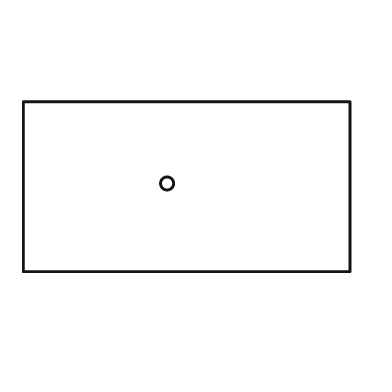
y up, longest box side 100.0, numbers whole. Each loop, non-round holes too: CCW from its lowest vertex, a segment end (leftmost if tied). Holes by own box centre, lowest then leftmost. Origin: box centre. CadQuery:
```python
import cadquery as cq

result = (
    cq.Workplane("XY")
    .moveTo(-50.0, -26.0)
    .lineTo(50.0, -26.0)
    .lineTo(50.0, 26.0)
    .lineTo(-50.0, 26.0)
    .close()
    .moveTo(-6.0, 1.0)
    .circle(2.0)
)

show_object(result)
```